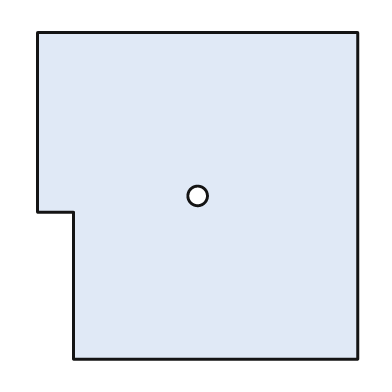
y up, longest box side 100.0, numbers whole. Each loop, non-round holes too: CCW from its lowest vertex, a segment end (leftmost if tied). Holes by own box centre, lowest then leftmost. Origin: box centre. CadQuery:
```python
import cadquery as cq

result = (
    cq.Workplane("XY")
    .moveTo(-38.0, -50.0)
    .lineTo(49.0, -50.0)
    .lineTo(49.0, 50.0)
    .lineTo(-49.0, 50.0)
    .lineTo(-49.0, -5.0)
    .lineTo(-38.0, -5.0)
    .close()
    .moveTo(0.0, 0.0)
    .circle(3.0)
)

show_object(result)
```